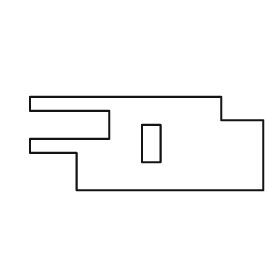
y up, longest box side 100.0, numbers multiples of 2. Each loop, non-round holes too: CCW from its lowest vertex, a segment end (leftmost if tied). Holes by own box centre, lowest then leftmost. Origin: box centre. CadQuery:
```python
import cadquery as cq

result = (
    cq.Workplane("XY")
    .moveTo(-30.0, -20.0)
    .lineTo(50.0, -20.0)
    .lineTo(50.0, 10.0)
    .lineTo(32.0, 10.0)
    .lineTo(32.0, 20.0)
    .lineTo(-50.0, 20.0)
    .lineTo(-50.0, 14.0)
    .lineTo(-16.0, 14.0)
    .lineTo(-16.0, 2.0)
    .lineTo(-50.0, 2.0)
    .lineTo(-50.0, -4.0)
    .lineTo(-30.0, -4.0)
    .close()
    .moveTo(-2.0, -8.0)
    .lineTo(6.0, -8.0)
    .lineTo(6.0, 8.0)
    .lineTo(-2.0, 8.0)
    .close()
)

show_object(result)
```